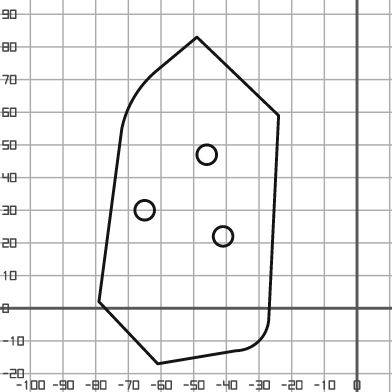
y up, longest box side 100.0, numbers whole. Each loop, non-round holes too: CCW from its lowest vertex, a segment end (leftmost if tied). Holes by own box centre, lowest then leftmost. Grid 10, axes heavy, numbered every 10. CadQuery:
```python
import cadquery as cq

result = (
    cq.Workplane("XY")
    .moveTo(-61.0, -17.0)
    .lineTo(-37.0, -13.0)
    .threePointArc((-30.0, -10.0), (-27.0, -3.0))
    .lineTo(-24.0, 59.0)
    .lineTo(-49.0, 83.0)
    .lineTo(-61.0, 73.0)
    .threePointArc((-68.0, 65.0), (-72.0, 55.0))
    .lineTo(-79.0, 2.0)
    .close()
    .moveTo(-41.0, 22.0)
    .circle(3.0)
    .moveTo(-65.0, 30.0)
    .circle(3.0)
    .moveTo(-46.0, 47.0)
    .circle(3.0)
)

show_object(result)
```